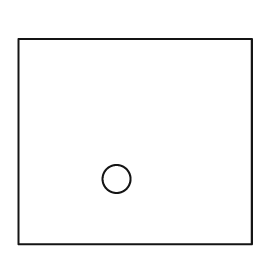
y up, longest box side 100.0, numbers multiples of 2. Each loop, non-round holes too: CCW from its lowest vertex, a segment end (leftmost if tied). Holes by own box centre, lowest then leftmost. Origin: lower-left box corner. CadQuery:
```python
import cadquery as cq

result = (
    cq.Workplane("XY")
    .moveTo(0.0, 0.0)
    .lineTo(100.0, 0.0)
    .lineTo(100.0, 88.0)
    .lineTo(0.0, 88.0)
    .close()
    .moveTo(42.0, 28.0)
    .circle(6.0)
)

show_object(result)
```